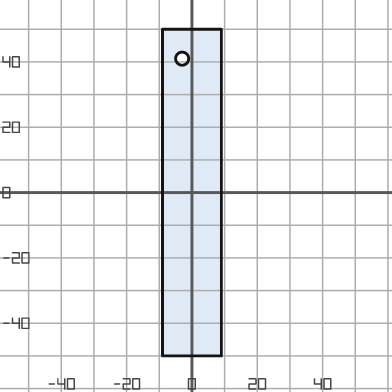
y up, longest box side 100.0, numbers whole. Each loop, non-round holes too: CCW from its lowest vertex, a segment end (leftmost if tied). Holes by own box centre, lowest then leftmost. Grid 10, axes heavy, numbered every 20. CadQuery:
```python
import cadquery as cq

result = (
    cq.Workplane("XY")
    .moveTo(-9.0, -50.0)
    .lineTo(9.0, -50.0)
    .lineTo(9.0, 50.0)
    .lineTo(-9.0, 50.0)
    .close()
    .moveTo(-3.0, 41.0)
    .circle(2.0)
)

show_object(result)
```